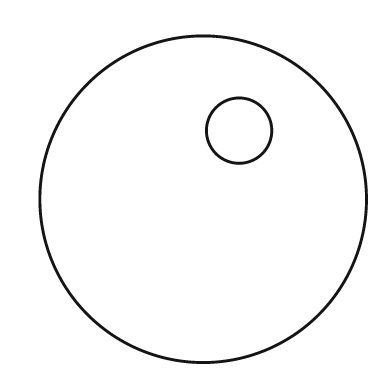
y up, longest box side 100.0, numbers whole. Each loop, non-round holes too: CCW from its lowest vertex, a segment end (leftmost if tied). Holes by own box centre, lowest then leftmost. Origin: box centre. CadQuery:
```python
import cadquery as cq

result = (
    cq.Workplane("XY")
    .moveTo(0.0, 0.0)
    .circle(50.0)
    .moveTo(11.0, 21.0)
    .circle(10.0)
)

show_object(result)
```